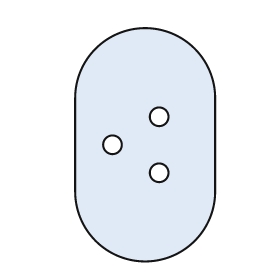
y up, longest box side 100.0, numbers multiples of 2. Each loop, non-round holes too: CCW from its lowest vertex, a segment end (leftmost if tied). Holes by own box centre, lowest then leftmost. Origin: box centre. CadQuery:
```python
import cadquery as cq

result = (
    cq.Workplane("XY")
    .moveTo(-30.0, -20.0)
    .threePointArc((0.0, -50.0), (30.0, -20.0))
    .lineTo(30.0, 20.0)
    .threePointArc((0.0, 50.0), (-30.0, 20.0))
    .close()
    .moveTo(6.0, -12.0)
    .circle(4.0)
    .moveTo(-14.0, 0.0)
    .circle(4.0)
    .moveTo(6.0, 12.0)
    .circle(4.0)
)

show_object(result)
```